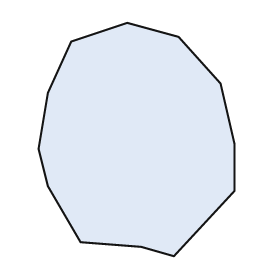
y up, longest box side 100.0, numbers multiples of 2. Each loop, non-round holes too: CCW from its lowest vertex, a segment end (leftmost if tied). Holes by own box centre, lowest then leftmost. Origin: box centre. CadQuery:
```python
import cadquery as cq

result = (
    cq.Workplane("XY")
    .moveTo(16.0, -50.0)
    .lineTo(42.0, -22.0)
    .lineTo(42.0, -2.0)
    .lineTo(36.0, 24.0)
    .lineTo(18.0, 44.0)
    .lineTo(-4.0, 50.0)
    .lineTo(-28.0, 42.0)
    .lineTo(-38.0, 20.0)
    .lineTo(-42.0, -4.0)
    .lineTo(-38.0, -20.0)
    .lineTo(-24.0, -44.0)
    .lineTo(2.0, -46.0)
    .close()
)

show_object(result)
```